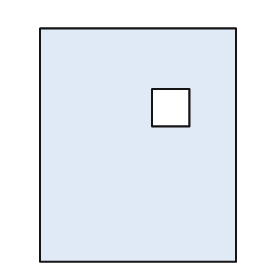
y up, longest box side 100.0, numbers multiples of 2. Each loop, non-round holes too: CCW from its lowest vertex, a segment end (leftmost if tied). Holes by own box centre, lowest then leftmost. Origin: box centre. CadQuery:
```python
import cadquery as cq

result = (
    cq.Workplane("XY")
    .moveTo(-42.0, -50.0)
    .lineTo(42.0, -50.0)
    .lineTo(42.0, 50.0)
    .lineTo(-42.0, 50.0)
    .close()
    .moveTo(6.0, 8.0)
    .lineTo(22.0, 8.0)
    .lineTo(22.0, 24.0)
    .lineTo(6.0, 24.0)
    .close()
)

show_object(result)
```